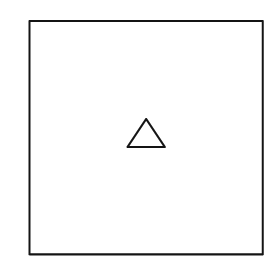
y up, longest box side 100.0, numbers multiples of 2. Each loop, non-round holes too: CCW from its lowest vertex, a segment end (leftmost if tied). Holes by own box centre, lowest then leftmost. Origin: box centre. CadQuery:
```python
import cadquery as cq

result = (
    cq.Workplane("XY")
    .moveTo(-50.0, -50.0)
    .lineTo(50.0, -50.0)
    .lineTo(50.0, 50.0)
    .lineTo(-50.0, 50.0)
    .close()
    .moveTo(-8.0, -4.0)
    .lineTo(8.0, -4.0)
    .lineTo(0.0, 8.0)
    .close()
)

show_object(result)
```